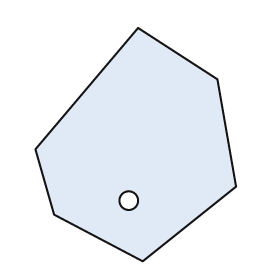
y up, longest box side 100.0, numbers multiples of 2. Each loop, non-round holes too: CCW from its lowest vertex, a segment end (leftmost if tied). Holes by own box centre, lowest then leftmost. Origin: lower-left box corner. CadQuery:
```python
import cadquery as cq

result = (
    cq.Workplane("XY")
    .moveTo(46.0, 0.0)
    .lineTo(86.0, 32.0)
    .lineTo(78.0, 78.0)
    .lineTo(44.0, 100.0)
    .lineTo(0.0, 48.0)
    .lineTo(8.0, 20.0)
    .close()
    .moveTo(40.0, 26.0)
    .circle(4.0)
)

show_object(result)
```